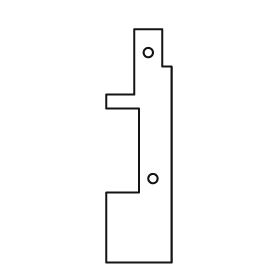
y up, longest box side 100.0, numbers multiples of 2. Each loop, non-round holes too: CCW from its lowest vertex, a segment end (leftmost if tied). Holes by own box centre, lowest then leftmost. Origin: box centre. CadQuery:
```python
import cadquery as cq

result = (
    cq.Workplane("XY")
    .moveTo(-14.0, -50.0)
    .lineTo(14.0, -50.0)
    .lineTo(14.0, 34.0)
    .lineTo(10.0, 34.0)
    .lineTo(10.0, 50.0)
    .lineTo(-2.0, 50.0)
    .lineTo(-2.0, 22.0)
    .lineTo(-14.0, 22.0)
    .lineTo(-14.0, 16.0)
    .lineTo(0.0, 16.0)
    .lineTo(0.0, -20.0)
    .lineTo(-14.0, -20.0)
    .close()
    .moveTo(6.0, -14.0)
    .circle(2.0)
    .moveTo(4.0, 40.0)
    .circle(2.0)
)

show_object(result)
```